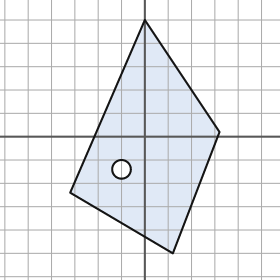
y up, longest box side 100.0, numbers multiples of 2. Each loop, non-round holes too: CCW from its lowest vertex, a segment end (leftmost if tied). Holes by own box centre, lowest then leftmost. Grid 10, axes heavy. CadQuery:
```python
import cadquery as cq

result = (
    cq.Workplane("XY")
    .moveTo(12.0, -50.0)
    .lineTo(32.0, 2.0)
    .lineTo(0.0, 50.0)
    .lineTo(-32.0, -24.0)
    .close()
    .moveTo(-10.0, -14.0)
    .circle(4.0)
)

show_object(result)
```